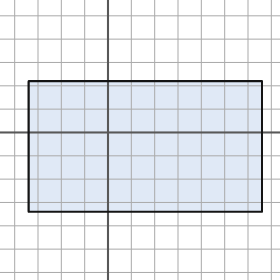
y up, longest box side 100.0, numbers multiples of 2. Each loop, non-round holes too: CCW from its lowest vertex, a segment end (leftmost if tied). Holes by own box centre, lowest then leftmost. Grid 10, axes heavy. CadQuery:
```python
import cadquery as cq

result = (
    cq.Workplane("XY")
    .moveTo(-34.0, -34.0)
    .lineTo(66.0, -34.0)
    .lineTo(66.0, 22.0)
    .lineTo(-34.0, 22.0)
    .close()
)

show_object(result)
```